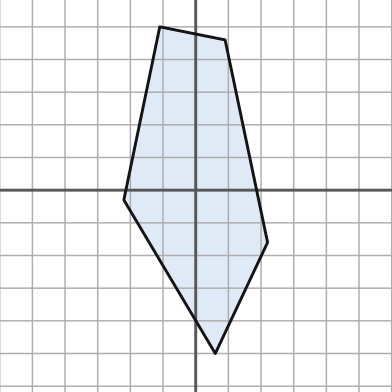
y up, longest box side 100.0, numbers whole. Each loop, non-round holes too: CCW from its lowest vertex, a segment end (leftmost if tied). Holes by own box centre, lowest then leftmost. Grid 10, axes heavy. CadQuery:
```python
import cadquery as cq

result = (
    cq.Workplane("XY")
    .moveTo(6.0, -50.0)
    .lineTo(22.0, -16.0)
    .lineTo(9.0, 46.0)
    .lineTo(-11.0, 50.0)
    .lineTo(-22.0, -3.0)
    .close()
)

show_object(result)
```